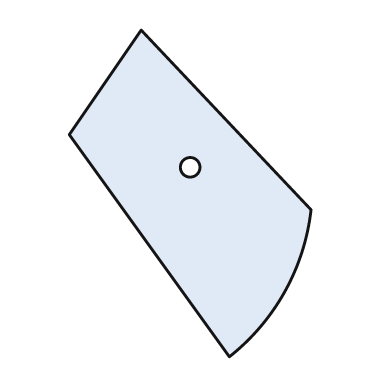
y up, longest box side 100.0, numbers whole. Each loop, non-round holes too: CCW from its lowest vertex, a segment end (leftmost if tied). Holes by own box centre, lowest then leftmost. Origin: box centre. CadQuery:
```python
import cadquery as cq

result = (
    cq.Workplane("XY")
    .moveTo(12.0, -50.0)
    .threePointArc((29.0, -30.0), (37.0, -5.0))
    .lineTo(-15.0, 50.0)
    .lineTo(-37.0, 18.0)
    .close()
    .moveTo(0.0, 8.0)
    .circle(3.0)
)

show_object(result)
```